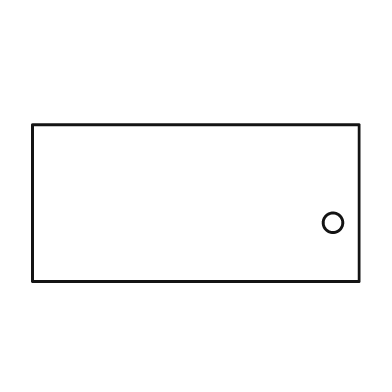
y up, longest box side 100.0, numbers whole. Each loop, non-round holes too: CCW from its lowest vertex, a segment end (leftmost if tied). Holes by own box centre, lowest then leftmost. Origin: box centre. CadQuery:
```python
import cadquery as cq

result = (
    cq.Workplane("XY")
    .moveTo(-50.0, -24.0)
    .lineTo(50.0, -24.0)
    .lineTo(50.0, 24.0)
    .lineTo(-50.0, 24.0)
    .close()
    .moveTo(42.0, -6.0)
    .circle(3.0)
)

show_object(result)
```